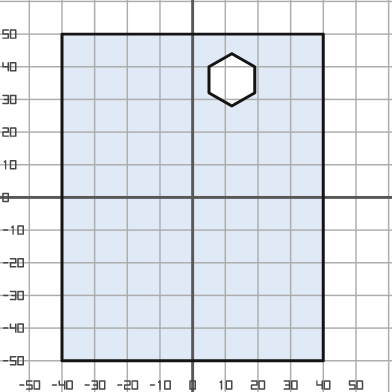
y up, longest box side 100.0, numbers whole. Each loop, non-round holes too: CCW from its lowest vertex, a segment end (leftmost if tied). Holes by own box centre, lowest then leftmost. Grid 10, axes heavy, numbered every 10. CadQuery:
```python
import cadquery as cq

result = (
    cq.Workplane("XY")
    .moveTo(-40.0, -50.0)
    .lineTo(40.0, -50.0)
    .lineTo(40.0, 50.0)
    .lineTo(-40.0, 50.0)
    .close()
    .moveTo(12.0, 28.0)
    .lineTo(19.0, 32.0)
    .lineTo(19.0, 40.0)
    .lineTo(12.0, 44.0)
    .lineTo(5.0, 40.0)
    .lineTo(5.0, 32.0)
    .close()
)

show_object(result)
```